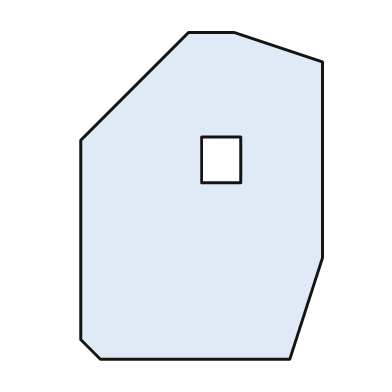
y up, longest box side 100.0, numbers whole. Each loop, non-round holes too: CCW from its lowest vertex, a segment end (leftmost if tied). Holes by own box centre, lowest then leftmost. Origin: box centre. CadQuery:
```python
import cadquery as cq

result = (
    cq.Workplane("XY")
    .moveTo(-31.0, -50.0)
    .lineTo(27.0, -50.0)
    .lineTo(37.0, -19.0)
    .lineTo(37.0, 41.0)
    .lineTo(10.0, 50.0)
    .lineTo(-4.0, 50.0)
    .lineTo(-37.0, 17.0)
    .lineTo(-37.0, -44.0)
    .close()
    .moveTo(0.0, 4.0)
    .lineTo(12.0, 4.0)
    .lineTo(12.0, 18.0)
    .lineTo(0.0, 18.0)
    .close()
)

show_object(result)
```